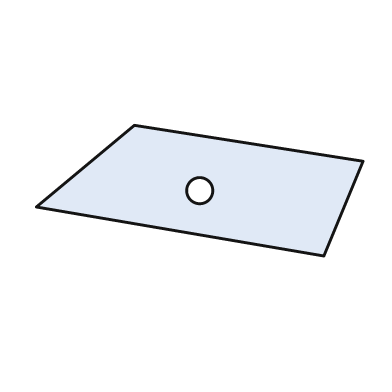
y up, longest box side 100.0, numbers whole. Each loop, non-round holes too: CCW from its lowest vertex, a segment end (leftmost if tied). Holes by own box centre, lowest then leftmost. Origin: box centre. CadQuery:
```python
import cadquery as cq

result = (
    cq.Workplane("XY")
    .moveTo(38.0, -20.0)
    .lineTo(50.0, 9.0)
    .lineTo(-20.0, 20.0)
    .lineTo(-50.0, -5.0)
    .close()
    .moveTo(0.0, 0.0)
    .circle(4.0)
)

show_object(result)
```